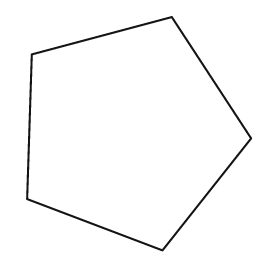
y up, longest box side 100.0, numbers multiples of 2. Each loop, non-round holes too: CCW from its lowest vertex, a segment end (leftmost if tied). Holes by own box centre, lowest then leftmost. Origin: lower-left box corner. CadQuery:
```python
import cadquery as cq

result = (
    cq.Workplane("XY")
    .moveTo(58.0, 0.0)
    .lineTo(96.0, 48.0)
    .lineTo(62.0, 100.0)
    .lineTo(2.0, 84.0)
    .lineTo(0.0, 22.0)
    .close()
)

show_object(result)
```